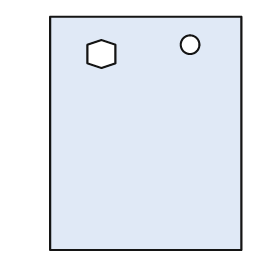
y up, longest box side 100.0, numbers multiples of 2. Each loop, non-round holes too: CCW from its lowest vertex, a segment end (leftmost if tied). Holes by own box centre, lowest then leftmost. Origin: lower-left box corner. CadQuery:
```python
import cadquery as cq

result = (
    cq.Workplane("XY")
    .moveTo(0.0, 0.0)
    .lineTo(82.0, 0.0)
    .lineTo(82.0, 100.0)
    .lineTo(0.0, 100.0)
    .close()
    .moveTo(22.0, 78.0)
    .lineTo(28.0, 80.0)
    .lineTo(28.0, 88.0)
    .lineTo(22.0, 90.0)
    .lineTo(16.0, 88.0)
    .lineTo(16.0, 80.0)
    .close()
    .moveTo(60.0, 88.0)
    .circle(4.0)
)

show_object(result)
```